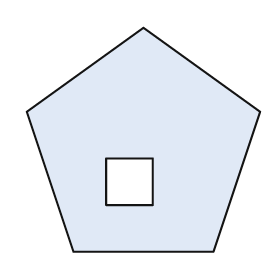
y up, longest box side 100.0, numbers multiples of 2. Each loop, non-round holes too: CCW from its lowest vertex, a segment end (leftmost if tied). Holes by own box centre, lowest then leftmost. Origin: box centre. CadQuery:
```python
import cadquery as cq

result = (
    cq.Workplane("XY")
    .moveTo(-30.0, -48.0)
    .lineTo(30.0, -48.0)
    .lineTo(50.0, 12.0)
    .lineTo(0.0, 48.0)
    .lineTo(-50.0, 12.0)
    .close()
    .moveTo(-16.0, -28.0)
    .lineTo(4.0, -28.0)
    .lineTo(4.0, -8.0)
    .lineTo(-16.0, -8.0)
    .close()
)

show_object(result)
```